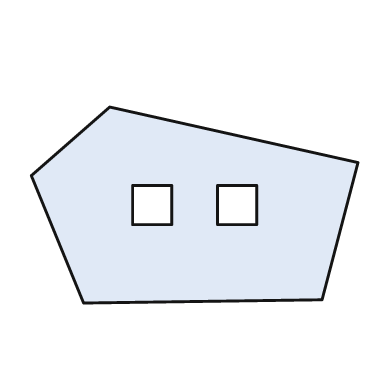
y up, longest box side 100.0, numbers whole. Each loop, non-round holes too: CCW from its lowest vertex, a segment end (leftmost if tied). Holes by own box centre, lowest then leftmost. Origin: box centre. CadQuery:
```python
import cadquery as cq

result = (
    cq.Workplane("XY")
    .moveTo(-34.0, -30.0)
    .lineTo(39.0, -29.0)
    .lineTo(50.0, 13.0)
    .lineTo(-26.0, 30.0)
    .lineTo(-50.0, 9.0)
    .close()
    .moveTo(-19.0, -6.0)
    .lineTo(-7.0, -6.0)
    .lineTo(-7.0, 6.0)
    .lineTo(-19.0, 6.0)
    .close()
    .moveTo(7.0, -6.0)
    .lineTo(19.0, -6.0)
    .lineTo(19.0, 6.0)
    .lineTo(7.0, 6.0)
    .close()
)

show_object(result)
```